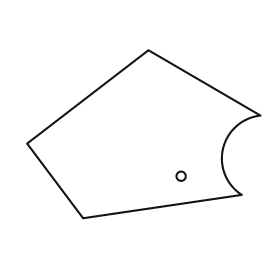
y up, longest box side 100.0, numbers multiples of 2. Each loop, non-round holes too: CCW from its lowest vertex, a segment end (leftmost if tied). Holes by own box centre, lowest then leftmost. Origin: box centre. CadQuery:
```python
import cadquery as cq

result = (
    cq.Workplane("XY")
    .moveTo(-26.0, -36.0)
    .lineTo(42.0, -26.0)
    .threePointArc((34.0, -6.0), (50.0, 8.0))
    .lineTo(2.0, 36.0)
    .lineTo(-50.0, -4.0)
    .close()
    .moveTo(16.0, -18.0)
    .circle(2.0)
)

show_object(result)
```